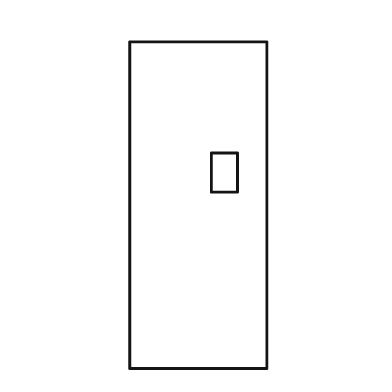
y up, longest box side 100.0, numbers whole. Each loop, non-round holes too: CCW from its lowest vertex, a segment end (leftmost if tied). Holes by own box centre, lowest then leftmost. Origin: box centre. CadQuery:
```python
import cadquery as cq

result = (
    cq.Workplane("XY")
    .moveTo(-21.0, -50.0)
    .lineTo(21.0, -50.0)
    .lineTo(21.0, 50.0)
    .lineTo(-21.0, 50.0)
    .close()
    .moveTo(4.0, 4.0)
    .lineTo(12.0, 4.0)
    .lineTo(12.0, 16.0)
    .lineTo(4.0, 16.0)
    .close()
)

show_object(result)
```